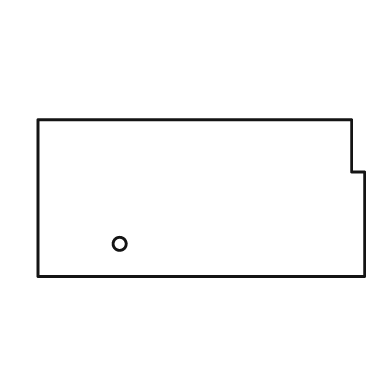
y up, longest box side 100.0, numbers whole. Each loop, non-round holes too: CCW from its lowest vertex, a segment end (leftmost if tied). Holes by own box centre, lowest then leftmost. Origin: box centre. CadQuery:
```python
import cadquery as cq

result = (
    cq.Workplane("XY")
    .moveTo(-50.0, -24.0)
    .lineTo(50.0, -24.0)
    .lineTo(50.0, 8.0)
    .lineTo(46.0, 8.0)
    .lineTo(46.0, 24.0)
    .lineTo(-50.0, 24.0)
    .close()
    .moveTo(-25.0, -14.0)
    .circle(2.0)
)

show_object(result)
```